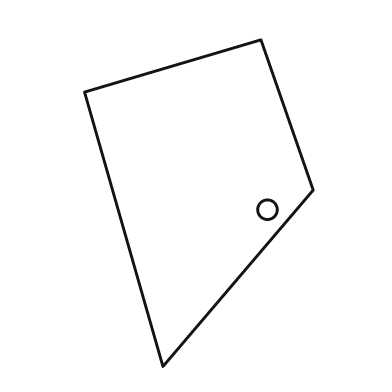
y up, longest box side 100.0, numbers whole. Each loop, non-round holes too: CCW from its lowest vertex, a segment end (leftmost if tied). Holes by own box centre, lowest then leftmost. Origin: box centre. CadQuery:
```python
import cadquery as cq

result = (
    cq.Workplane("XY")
    .moveTo(-11.0, -50.0)
    .lineTo(35.0, 4.0)
    .lineTo(19.0, 50.0)
    .lineTo(-35.0, 34.0)
    .close()
    .moveTo(21.0, -2.0)
    .circle(3.0)
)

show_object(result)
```